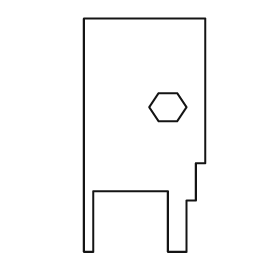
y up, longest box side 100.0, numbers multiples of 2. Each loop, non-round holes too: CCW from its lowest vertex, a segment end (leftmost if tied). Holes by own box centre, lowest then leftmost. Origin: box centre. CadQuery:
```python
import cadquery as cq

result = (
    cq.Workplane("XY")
    .moveTo(-26.0, -50.0)
    .lineTo(-22.0, -50.0)
    .lineTo(-22.0, -24.0)
    .lineTo(10.0, -24.0)
    .lineTo(10.0, -50.0)
    .lineTo(18.0, -50.0)
    .lineTo(18.0, -28.0)
    .lineTo(22.0, -28.0)
    .lineTo(22.0, -12.0)
    .lineTo(26.0, -12.0)
    .lineTo(26.0, 50.0)
    .lineTo(-26.0, 50.0)
    .close()
    .moveTo(6.0, 6.0)
    .lineTo(14.0, 6.0)
    .lineTo(18.0, 12.0)
    .lineTo(14.0, 18.0)
    .lineTo(6.0, 18.0)
    .lineTo(2.0, 12.0)
    .close()
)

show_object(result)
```